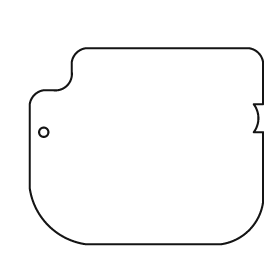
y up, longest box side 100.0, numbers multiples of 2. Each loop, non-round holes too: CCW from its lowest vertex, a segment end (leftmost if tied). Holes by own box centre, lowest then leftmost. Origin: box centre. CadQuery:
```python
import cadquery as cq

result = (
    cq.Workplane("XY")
    .moveTo(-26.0, -42.0)
    .lineTo(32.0, -42.0)
    .threePointArc((44.0, -36.0), (50.0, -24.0))
    .lineTo(50.0, 6.0)
    .lineTo(46.0, 6.0)
    .threePointArc((48.0, 12.0), (46.0, 18.0))
    .lineTo(50.0, 18.0)
    .lineTo(50.0, 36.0)
    .threePointArc((48.0, 40.0), (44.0, 42.0))
    .lineTo(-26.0, 42.0)
    .threePointArc((-30.0, 40.0), (-32.0, 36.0))
    .lineTo(-32.0, 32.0)
    .threePointArc((-34.0, 26.0), (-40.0, 24.0))
    .lineTo(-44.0, 24.0)
    .threePointArc((-48.0, 22.0), (-50.0, 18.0))
    .lineTo(-50.0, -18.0)
    .threePointArc((-42.0, -34.0), (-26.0, -42.0))
    .close()
    .moveTo(-44.0, 6.0)
    .circle(2.0)
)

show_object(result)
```